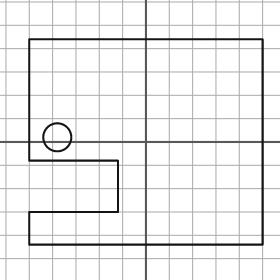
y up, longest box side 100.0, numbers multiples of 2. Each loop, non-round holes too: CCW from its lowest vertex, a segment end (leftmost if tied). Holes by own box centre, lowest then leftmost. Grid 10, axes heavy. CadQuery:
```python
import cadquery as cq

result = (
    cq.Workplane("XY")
    .moveTo(-50.0, -44.0)
    .lineTo(50.0, -44.0)
    .lineTo(50.0, 44.0)
    .lineTo(-50.0, 44.0)
    .lineTo(-50.0, -8.0)
    .lineTo(-12.0, -8.0)
    .lineTo(-12.0, -30.0)
    .lineTo(-50.0, -30.0)
    .close()
    .moveTo(-38.0, 2.0)
    .circle(6.0)
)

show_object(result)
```